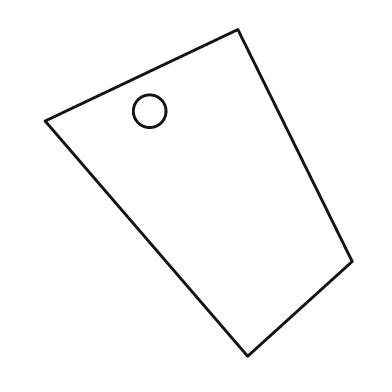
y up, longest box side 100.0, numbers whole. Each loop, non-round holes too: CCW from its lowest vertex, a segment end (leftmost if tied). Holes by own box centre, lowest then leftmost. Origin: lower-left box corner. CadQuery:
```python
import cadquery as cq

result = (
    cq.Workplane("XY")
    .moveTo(62.0, 0.0)
    .lineTo(94.0, 29.0)
    .lineTo(59.0, 100.0)
    .lineTo(0.0, 72.0)
    .close()
    .moveTo(32.0, 75.0)
    .circle(5.0)
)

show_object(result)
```